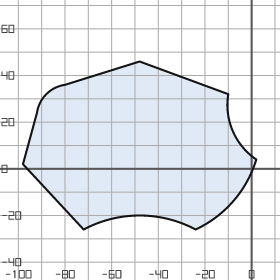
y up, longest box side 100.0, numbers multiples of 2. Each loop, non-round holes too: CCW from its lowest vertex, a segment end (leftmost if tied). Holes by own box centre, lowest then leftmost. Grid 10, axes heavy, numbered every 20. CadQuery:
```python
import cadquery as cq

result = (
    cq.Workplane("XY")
    .moveTo(-72.0, -26.0)
    .threePointArc((-48.0, -20.0), (-24.0, -26.0))
    .threePointArc((-8.0, -14.0), (2.0, 4.0))
    .threePointArc((-8.0, 16.0), (-10.0, 32.0))
    .lineTo(-48.0, 46.0)
    .lineTo(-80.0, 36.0)
    .threePointArc((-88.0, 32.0), (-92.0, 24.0))
    .lineTo(-98.0, 2.0)
    .close()
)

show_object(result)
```